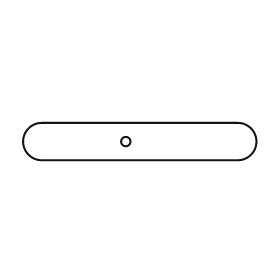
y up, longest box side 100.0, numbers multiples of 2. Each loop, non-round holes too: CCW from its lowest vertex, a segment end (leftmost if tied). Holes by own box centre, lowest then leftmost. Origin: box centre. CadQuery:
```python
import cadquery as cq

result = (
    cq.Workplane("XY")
    .moveTo(-42.0, -8.0)
    .lineTo(42.0, -8.0)
    .threePointArc((50.0, 0.0), (42.0, 8.0))
    .lineTo(-42.0, 8.0)
    .threePointArc((-50.0, 0.0), (-42.0, -8.0))
    .close()
    .moveTo(-6.0, 0.0)
    .circle(2.0)
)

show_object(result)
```